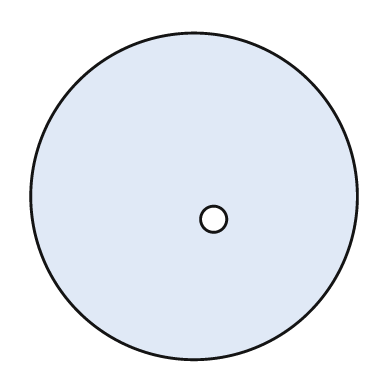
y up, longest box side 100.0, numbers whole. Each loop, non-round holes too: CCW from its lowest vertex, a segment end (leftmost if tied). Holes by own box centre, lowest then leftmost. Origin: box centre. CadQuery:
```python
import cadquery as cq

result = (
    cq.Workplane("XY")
    .moveTo(0.0, 0.0)
    .circle(50.0)
    .moveTo(6.0, -7.0)
    .circle(4.0)
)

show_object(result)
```